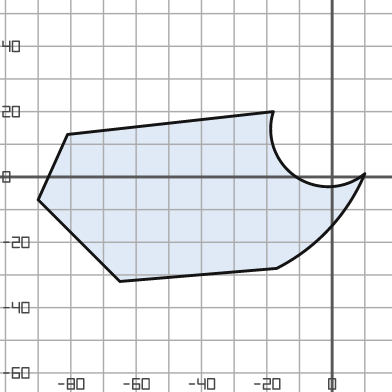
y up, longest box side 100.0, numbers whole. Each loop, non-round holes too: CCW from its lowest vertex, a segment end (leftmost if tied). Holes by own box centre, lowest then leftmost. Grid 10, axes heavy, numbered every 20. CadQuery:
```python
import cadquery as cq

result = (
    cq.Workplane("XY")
    .moveTo(-65.0, -32.0)
    .lineTo(-17.0, -28.0)
    .threePointArc((-1.0, -16.0), (10.0, 1.0))
    .threePointArc((-11.0, 0.0), (-18.0, 20.0))
    .lineTo(-81.0, 13.0)
    .lineTo(-90.0, -7.0)
    .close()
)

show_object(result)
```